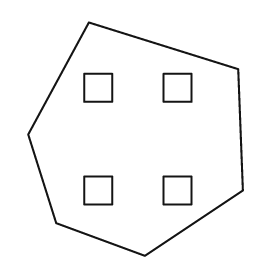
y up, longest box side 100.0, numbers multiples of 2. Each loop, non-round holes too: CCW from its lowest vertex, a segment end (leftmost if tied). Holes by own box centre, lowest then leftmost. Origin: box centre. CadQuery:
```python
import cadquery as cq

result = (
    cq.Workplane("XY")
    .moveTo(4.0, -50.0)
    .lineTo(46.0, -22.0)
    .lineTo(44.0, 30.0)
    .lineTo(-20.0, 50.0)
    .lineTo(-46.0, 2.0)
    .lineTo(-34.0, -36.0)
    .close()
    .moveTo(-22.0, -28.0)
    .lineTo(-10.0, -28.0)
    .lineTo(-10.0, -16.0)
    .lineTo(-22.0, -16.0)
    .close()
    .moveTo(12.0, -28.0)
    .lineTo(24.0, -28.0)
    .lineTo(24.0, -16.0)
    .lineTo(12.0, -16.0)
    .close()
    .moveTo(-22.0, 16.0)
    .lineTo(-10.0, 16.0)
    .lineTo(-10.0, 28.0)
    .lineTo(-22.0, 28.0)
    .close()
    .moveTo(12.0, 16.0)
    .lineTo(24.0, 16.0)
    .lineTo(24.0, 28.0)
    .lineTo(12.0, 28.0)
    .close()
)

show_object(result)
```